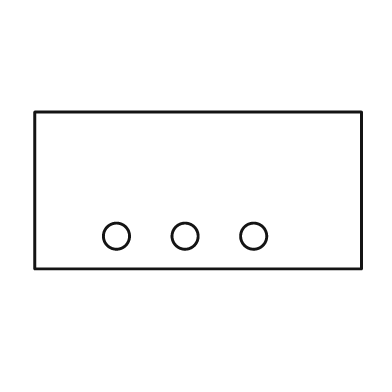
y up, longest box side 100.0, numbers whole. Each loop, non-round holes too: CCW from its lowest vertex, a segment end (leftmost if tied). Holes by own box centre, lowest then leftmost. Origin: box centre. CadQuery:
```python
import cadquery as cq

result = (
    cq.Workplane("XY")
    .moveTo(-50.0, -24.0)
    .lineTo(50.0, -24.0)
    .lineTo(50.0, 24.0)
    .lineTo(-50.0, 24.0)
    .close()
    .moveTo(-25.0, -14.0)
    .circle(4.0)
    .moveTo(-4.0, -14.0)
    .circle(4.0)
    .moveTo(17.0, -14.0)
    .circle(4.0)
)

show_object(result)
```